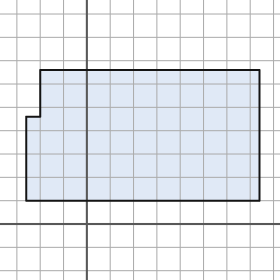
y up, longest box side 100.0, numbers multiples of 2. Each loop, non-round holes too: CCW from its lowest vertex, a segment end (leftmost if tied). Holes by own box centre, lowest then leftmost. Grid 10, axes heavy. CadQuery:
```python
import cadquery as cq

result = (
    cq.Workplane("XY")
    .moveTo(-26.0, 10.0)
    .lineTo(74.0, 10.0)
    .lineTo(74.0, 66.0)
    .lineTo(-20.0, 66.0)
    .lineTo(-20.0, 46.0)
    .lineTo(-26.0, 46.0)
    .close()
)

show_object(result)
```